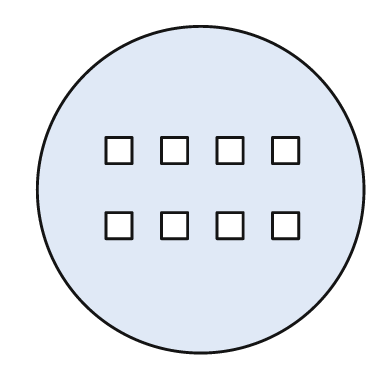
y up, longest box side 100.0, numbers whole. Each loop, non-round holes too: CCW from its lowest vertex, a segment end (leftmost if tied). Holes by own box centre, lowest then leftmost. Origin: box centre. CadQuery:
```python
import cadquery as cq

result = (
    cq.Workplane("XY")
    .moveTo(0.0, 0.0)
    .circle(50.0)
    .moveTo(-29.0, -15.0)
    .lineTo(-21.0, -15.0)
    .lineTo(-21.0, -7.0)
    .lineTo(-29.0, -7.0)
    .close()
    .moveTo(-12.0, -15.0)
    .lineTo(-4.0, -15.0)
    .lineTo(-4.0, -7.0)
    .lineTo(-12.0, -7.0)
    .close()
    .moveTo(5.0, -15.0)
    .lineTo(13.0, -15.0)
    .lineTo(13.0, -7.0)
    .lineTo(5.0, -7.0)
    .close()
    .moveTo(22.0, -15.0)
    .lineTo(30.0, -15.0)
    .lineTo(30.0, -7.0)
    .lineTo(22.0, -7.0)
    .close()
    .moveTo(-29.0, 8.0)
    .lineTo(-21.0, 8.0)
    .lineTo(-21.0, 16.0)
    .lineTo(-29.0, 16.0)
    .close()
    .moveTo(-12.0, 8.0)
    .lineTo(-4.0, 8.0)
    .lineTo(-4.0, 16.0)
    .lineTo(-12.0, 16.0)
    .close()
    .moveTo(5.0, 8.0)
    .lineTo(13.0, 8.0)
    .lineTo(13.0, 16.0)
    .lineTo(5.0, 16.0)
    .close()
    .moveTo(22.0, 8.0)
    .lineTo(30.0, 8.0)
    .lineTo(30.0, 16.0)
    .lineTo(22.0, 16.0)
    .close()
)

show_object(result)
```